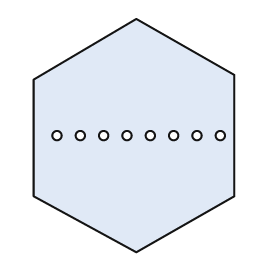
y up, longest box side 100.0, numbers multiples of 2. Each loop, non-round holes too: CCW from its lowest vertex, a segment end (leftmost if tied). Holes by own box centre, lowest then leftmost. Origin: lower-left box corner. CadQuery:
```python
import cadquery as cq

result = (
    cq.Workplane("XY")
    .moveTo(44.0, 0.0)
    .lineTo(86.0, 24.0)
    .lineTo(86.0, 76.0)
    .lineTo(44.0, 100.0)
    .lineTo(0.0, 74.0)
    .lineTo(0.0, 24.0)
    .close()
    .moveTo(10.0, 50.0)
    .circle(2.0)
    .moveTo(20.0, 50.0)
    .circle(2.0)
    .moveTo(30.0, 50.0)
    .circle(2.0)
    .moveTo(40.0, 50.0)
    .circle(2.0)
    .moveTo(50.0, 50.0)
    .circle(2.0)
    .moveTo(60.0, 50.0)
    .circle(2.0)
    .moveTo(70.0, 50.0)
    .circle(2.0)
    .moveTo(80.0, 50.0)
    .circle(2.0)
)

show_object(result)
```